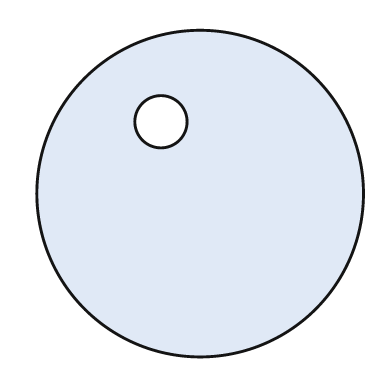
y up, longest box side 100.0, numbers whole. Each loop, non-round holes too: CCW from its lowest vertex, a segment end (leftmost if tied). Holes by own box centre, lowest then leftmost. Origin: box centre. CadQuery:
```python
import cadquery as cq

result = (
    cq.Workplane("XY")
    .moveTo(0.0, 0.0)
    .circle(50.0)
    .moveTo(-12.0, 22.0)
    .circle(8.0)
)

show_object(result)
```